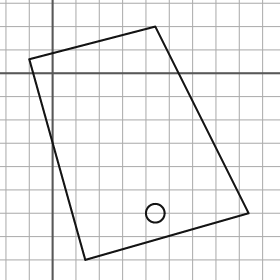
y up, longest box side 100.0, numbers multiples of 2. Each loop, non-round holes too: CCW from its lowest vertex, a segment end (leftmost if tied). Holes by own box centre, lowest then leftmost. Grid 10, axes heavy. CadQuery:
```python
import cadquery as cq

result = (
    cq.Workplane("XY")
    .moveTo(14.0, -80.0)
    .lineTo(84.0, -60.0)
    .lineTo(44.0, 20.0)
    .lineTo(-10.0, 6.0)
    .close()
    .moveTo(44.0, -60.0)
    .circle(4.0)
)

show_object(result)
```